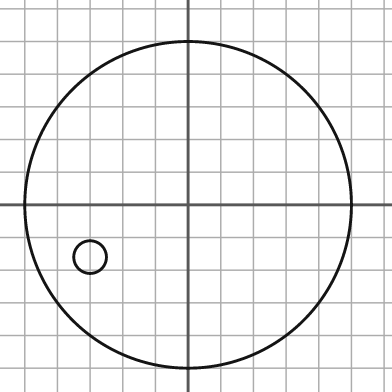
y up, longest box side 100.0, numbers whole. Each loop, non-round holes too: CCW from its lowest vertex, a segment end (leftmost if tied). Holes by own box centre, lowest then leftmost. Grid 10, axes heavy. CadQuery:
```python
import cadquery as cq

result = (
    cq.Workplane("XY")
    .moveTo(0.0, 0.0)
    .circle(50.0)
    .moveTo(-30.0, -16.0)
    .circle(5.0)
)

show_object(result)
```